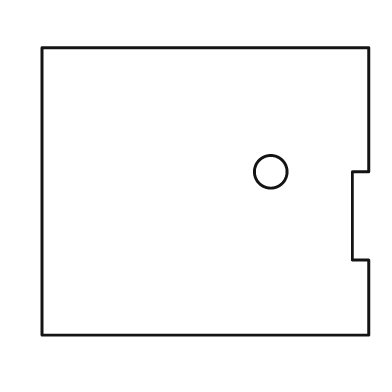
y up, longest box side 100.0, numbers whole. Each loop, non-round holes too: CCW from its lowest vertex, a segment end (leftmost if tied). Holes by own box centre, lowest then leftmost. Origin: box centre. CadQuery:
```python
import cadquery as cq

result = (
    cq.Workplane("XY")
    .moveTo(-50.0, -44.0)
    .lineTo(50.0, -44.0)
    .lineTo(50.0, -21.0)
    .lineTo(45.0, -21.0)
    .lineTo(45.0, 6.0)
    .lineTo(50.0, 6.0)
    .lineTo(50.0, 44.0)
    .lineTo(-50.0, 44.0)
    .close()
    .moveTo(20.0, 6.0)
    .circle(5.0)
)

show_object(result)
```